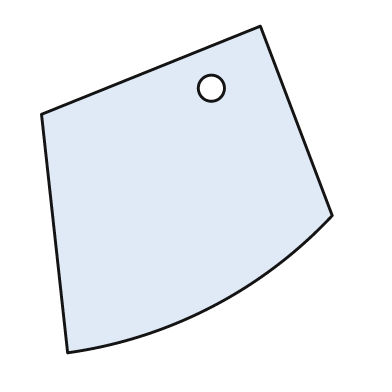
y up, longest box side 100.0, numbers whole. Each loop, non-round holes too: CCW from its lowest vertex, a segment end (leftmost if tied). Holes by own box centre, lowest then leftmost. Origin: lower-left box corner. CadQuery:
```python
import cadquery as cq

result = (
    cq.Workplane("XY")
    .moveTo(8.0, 0.0)
    .threePointArc((52.0, 14.0), (89.0, 42.0))
    .lineTo(67.0, 100.0)
    .lineTo(0.0, 73.0)
    .close()
    .moveTo(52.0, 81.0)
    .circle(4.0)
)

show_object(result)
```